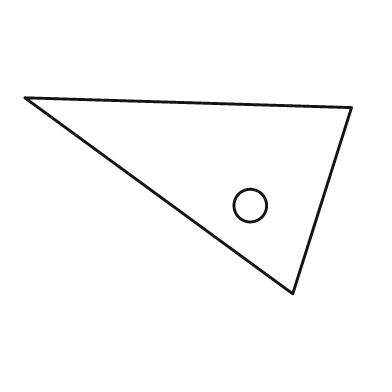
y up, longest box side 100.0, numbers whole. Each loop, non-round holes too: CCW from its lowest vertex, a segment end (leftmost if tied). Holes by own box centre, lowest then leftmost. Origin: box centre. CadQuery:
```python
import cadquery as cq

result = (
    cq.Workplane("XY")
    .moveTo(32.0, -30.0)
    .lineTo(50.0, 27.0)
    .lineTo(-50.0, 30.0)
    .close()
    .moveTo(19.0, -3.0)
    .circle(5.0)
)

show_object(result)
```